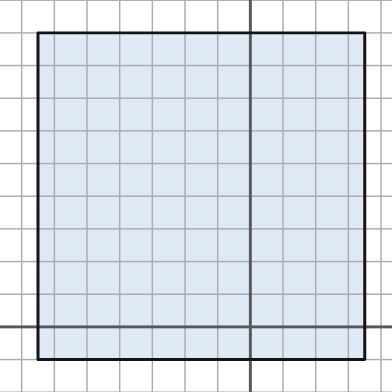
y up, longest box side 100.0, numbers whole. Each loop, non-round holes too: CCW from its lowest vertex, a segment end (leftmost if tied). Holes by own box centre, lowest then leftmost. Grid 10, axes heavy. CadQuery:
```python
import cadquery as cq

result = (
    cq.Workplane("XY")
    .moveTo(-65.0, -10.0)
    .lineTo(35.0, -10.0)
    .lineTo(35.0, 90.0)
    .lineTo(-65.0, 90.0)
    .close()
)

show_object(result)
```